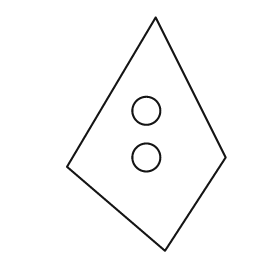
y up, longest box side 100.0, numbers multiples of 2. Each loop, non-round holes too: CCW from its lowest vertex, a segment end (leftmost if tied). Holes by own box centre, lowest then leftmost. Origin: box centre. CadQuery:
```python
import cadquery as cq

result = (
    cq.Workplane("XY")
    .moveTo(8.0, -50.0)
    .lineTo(34.0, -10.0)
    .lineTo(4.0, 50.0)
    .lineTo(-34.0, -14.0)
    .close()
    .moveTo(0.0, -10.0)
    .circle(6.0)
    .moveTo(0.0, 10.0)
    .circle(6.0)
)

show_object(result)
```